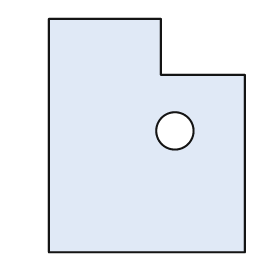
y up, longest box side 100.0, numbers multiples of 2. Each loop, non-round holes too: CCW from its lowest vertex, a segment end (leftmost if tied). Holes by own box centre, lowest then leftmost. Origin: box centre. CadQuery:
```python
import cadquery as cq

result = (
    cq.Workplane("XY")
    .moveTo(-42.0, -50.0)
    .lineTo(42.0, -50.0)
    .lineTo(42.0, 26.0)
    .lineTo(6.0, 26.0)
    .lineTo(6.0, 50.0)
    .lineTo(-42.0, 50.0)
    .close()
    .moveTo(12.0, 2.0)
    .circle(8.0)
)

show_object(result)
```